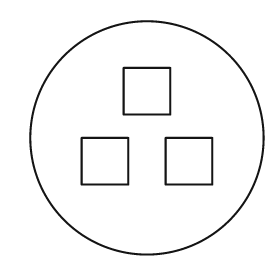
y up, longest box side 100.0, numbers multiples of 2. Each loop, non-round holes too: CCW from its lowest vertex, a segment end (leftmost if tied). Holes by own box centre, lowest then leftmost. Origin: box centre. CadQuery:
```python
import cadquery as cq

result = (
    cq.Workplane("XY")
    .moveTo(0.0, 0.0)
    .circle(50.0)
    .moveTo(-28.0, -20.0)
    .lineTo(-8.0, -20.0)
    .lineTo(-8.0, 0.0)
    .lineTo(-28.0, 0.0)
    .close()
    .moveTo(8.0, -20.0)
    .lineTo(28.0, -20.0)
    .lineTo(28.0, 0.0)
    .lineTo(8.0, 0.0)
    .close()
    .moveTo(-10.0, 10.0)
    .lineTo(10.0, 10.0)
    .lineTo(10.0, 30.0)
    .lineTo(-10.0, 30.0)
    .close()
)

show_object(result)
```